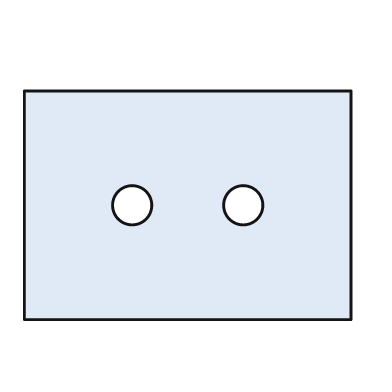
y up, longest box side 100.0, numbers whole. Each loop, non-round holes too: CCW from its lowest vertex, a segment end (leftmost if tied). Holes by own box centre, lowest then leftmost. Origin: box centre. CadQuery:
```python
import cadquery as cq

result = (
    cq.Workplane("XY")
    .moveTo(-50.0, -35.0)
    .lineTo(50.0, -35.0)
    .lineTo(50.0, 35.0)
    .lineTo(-50.0, 35.0)
    .close()
    .moveTo(-17.0, 0.0)
    .circle(6.0)
    .moveTo(17.0, 0.0)
    .circle(6.0)
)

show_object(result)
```